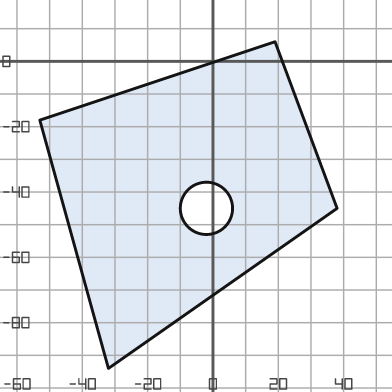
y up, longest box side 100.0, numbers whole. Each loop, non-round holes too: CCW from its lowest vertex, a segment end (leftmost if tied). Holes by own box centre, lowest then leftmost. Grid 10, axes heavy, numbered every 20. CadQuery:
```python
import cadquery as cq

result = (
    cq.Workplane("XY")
    .moveTo(-32.0, -94.0)
    .lineTo(38.0, -45.0)
    .lineTo(19.0, 6.0)
    .lineTo(-53.0, -18.0)
    .close()
    .moveTo(-2.0, -45.0)
    .circle(8.0)
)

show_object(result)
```